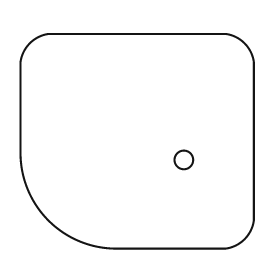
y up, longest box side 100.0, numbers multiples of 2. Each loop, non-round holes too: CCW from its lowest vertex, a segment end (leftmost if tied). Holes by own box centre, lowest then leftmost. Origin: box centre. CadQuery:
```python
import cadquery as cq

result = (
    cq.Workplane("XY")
    .moveTo(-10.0, -46.0)
    .lineTo(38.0, -46.0)
    .threePointArc((46.0, -42.0), (50.0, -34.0))
    .lineTo(50.0, 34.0)
    .threePointArc((46.0, 42.0), (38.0, 46.0))
    .lineTo(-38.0, 46.0)
    .threePointArc((-46.0, 42.0), (-50.0, 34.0))
    .lineTo(-50.0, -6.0)
    .threePointArc((-38.0, -34.0), (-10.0, -46.0))
    .close()
    .moveTo(20.0, -8.0)
    .circle(4.0)
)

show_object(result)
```